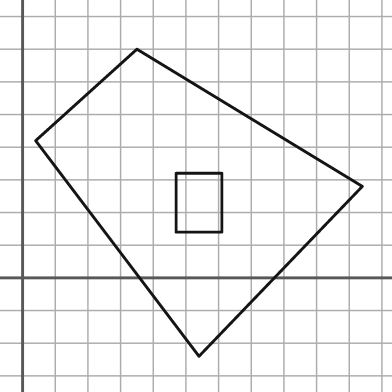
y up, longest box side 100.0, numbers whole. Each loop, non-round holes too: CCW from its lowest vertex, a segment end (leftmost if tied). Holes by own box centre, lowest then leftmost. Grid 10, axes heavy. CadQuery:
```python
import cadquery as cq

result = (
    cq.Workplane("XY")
    .moveTo(54.0, -24.0)
    .lineTo(104.0, 28.0)
    .lineTo(35.0, 70.0)
    .lineTo(4.0, 42.0)
    .close()
    .moveTo(47.0, 14.0)
    .lineTo(61.0, 14.0)
    .lineTo(61.0, 32.0)
    .lineTo(47.0, 32.0)
    .close()
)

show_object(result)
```